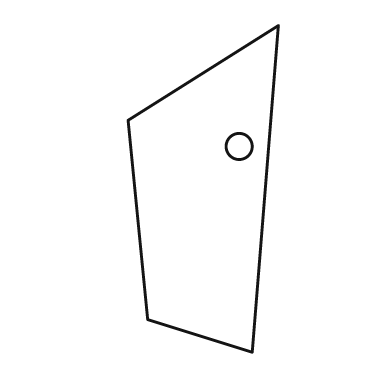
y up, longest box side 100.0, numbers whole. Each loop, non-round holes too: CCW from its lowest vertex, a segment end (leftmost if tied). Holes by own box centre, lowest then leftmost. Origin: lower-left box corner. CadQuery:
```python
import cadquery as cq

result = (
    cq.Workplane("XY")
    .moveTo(38.0, 0.0)
    .lineTo(46.0, 100.0)
    .lineTo(0.0, 71.0)
    .lineTo(6.0, 10.0)
    .close()
    .moveTo(34.0, 63.0)
    .circle(4.0)
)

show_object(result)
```